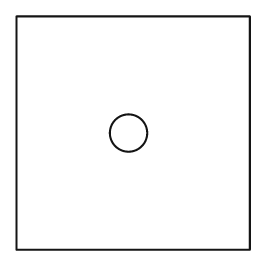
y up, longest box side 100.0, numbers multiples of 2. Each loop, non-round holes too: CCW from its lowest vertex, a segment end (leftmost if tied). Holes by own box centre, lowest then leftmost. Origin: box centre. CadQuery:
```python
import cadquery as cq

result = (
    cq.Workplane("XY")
    .moveTo(-50.0, -50.0)
    .lineTo(50.0, -50.0)
    .lineTo(50.0, 50.0)
    .lineTo(-50.0, 50.0)
    .close()
    .moveTo(-2.0, 0.0)
    .circle(8.0)
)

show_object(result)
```